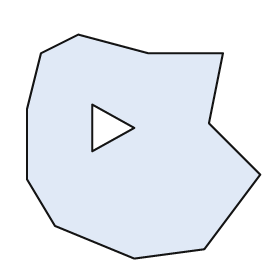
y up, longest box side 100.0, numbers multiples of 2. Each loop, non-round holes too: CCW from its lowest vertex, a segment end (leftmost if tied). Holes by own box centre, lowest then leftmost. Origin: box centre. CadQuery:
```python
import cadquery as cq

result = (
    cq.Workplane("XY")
    .moveTo(-4.0, -48.0)
    .lineTo(26.0, -44.0)
    .lineTo(50.0, -12.0)
    .lineTo(28.0, 10.0)
    .lineTo(34.0, 40.0)
    .lineTo(2.0, 40.0)
    .lineTo(-28.0, 48.0)
    .lineTo(-44.0, 40.0)
    .lineTo(-50.0, 16.0)
    .lineTo(-50.0, -14.0)
    .lineTo(-38.0, -34.0)
    .close()
    .moveTo(-22.0, -2.0)
    .lineTo(-4.0, 8.0)
    .lineTo(-22.0, 18.0)
    .close()
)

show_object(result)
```